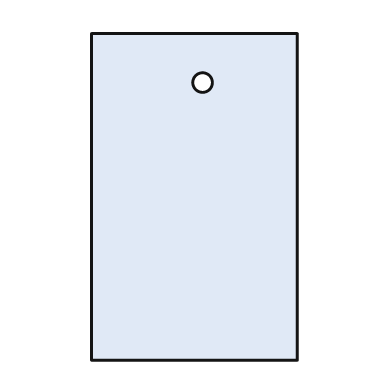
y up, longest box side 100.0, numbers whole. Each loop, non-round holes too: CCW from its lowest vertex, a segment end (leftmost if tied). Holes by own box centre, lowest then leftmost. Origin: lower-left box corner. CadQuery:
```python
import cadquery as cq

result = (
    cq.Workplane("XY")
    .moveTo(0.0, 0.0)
    .lineTo(63.0, 0.0)
    .lineTo(63.0, 100.0)
    .lineTo(0.0, 100.0)
    .close()
    .moveTo(34.0, 85.0)
    .circle(3.0)
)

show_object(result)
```